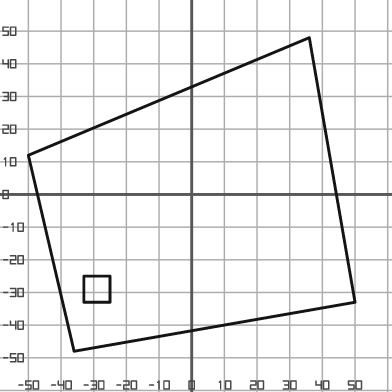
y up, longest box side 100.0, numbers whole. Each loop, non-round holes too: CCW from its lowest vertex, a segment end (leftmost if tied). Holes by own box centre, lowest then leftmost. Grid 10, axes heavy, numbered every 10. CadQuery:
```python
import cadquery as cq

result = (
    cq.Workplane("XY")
    .moveTo(-36.0, -48.0)
    .lineTo(50.0, -33.0)
    .lineTo(36.0, 48.0)
    .lineTo(-50.0, 12.0)
    .close()
    .moveTo(-33.0, -33.0)
    .lineTo(-25.0, -33.0)
    .lineTo(-25.0, -25.0)
    .lineTo(-33.0, -25.0)
    .close()
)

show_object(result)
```